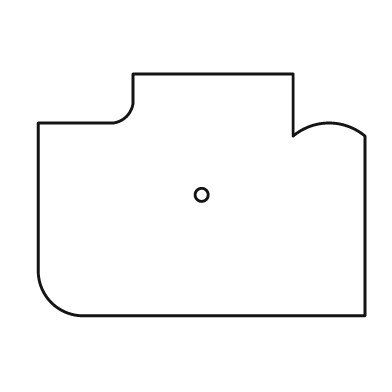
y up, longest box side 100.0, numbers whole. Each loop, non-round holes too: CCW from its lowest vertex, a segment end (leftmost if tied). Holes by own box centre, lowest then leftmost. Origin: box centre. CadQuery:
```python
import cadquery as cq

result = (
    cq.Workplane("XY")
    .moveTo(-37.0, -37.0)
    .lineTo(50.0, -37.0)
    .lineTo(50.0, 18.0)
    .threePointArc((39.0, 22.0), (28.0, 18.0))
    .lineTo(28.0, 37.0)
    .lineTo(-21.0, 37.0)
    .lineTo(-21.0, 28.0)
    .threePointArc((-23.0, 24.0), (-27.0, 22.0))
    .lineTo(-50.0, 22.0)
    .lineTo(-50.0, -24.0)
    .threePointArc((-46.0, -33.0), (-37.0, -37.0))
    .close()
    .moveTo(0.0, 0.0)
    .circle(2.0)
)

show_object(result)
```